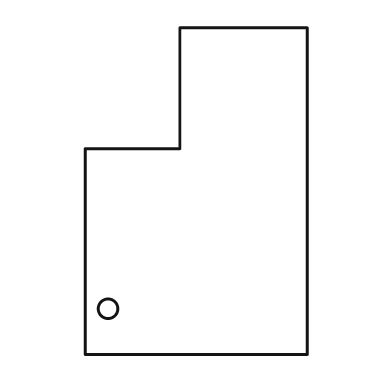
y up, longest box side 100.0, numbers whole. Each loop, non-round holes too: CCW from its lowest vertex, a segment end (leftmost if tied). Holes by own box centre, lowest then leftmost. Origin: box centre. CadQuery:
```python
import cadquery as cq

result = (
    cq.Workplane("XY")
    .moveTo(-34.0, -50.0)
    .lineTo(34.0, -50.0)
    .lineTo(34.0, 50.0)
    .lineTo(-5.0, 50.0)
    .lineTo(-5.0, 13.0)
    .lineTo(-34.0, 13.0)
    .close()
    .moveTo(-27.0, -36.0)
    .circle(3.0)
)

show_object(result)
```